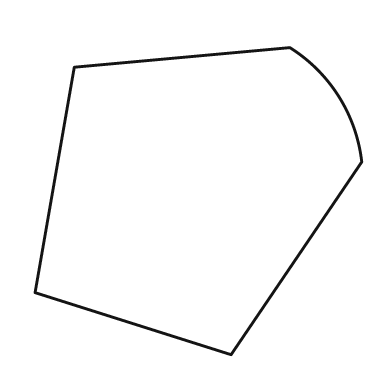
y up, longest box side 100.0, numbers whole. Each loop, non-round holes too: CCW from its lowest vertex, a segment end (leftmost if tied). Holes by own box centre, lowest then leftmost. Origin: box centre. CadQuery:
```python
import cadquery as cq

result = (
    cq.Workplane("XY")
    .moveTo(10.0, -47.0)
    .lineTo(50.0, 12.0)
    .threePointArc((43.0, 32.0), (28.0, 47.0))
    .lineTo(-38.0, 41.0)
    .lineTo(-50.0, -28.0)
    .close()
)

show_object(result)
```